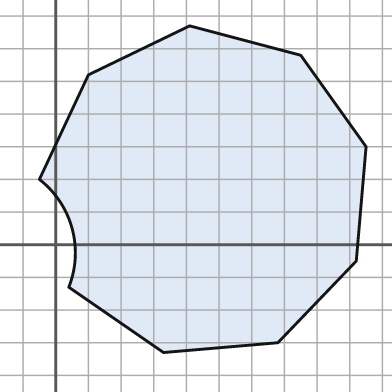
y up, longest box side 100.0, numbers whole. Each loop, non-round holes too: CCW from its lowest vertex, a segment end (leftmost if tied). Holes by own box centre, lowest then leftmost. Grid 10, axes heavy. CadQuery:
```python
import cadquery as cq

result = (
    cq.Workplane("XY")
    .moveTo(33.0, -33.0)
    .lineTo(68.0, -30.0)
    .lineTo(92.0, -5.0)
    .lineTo(95.0, 30.0)
    .lineTo(75.0, 58.0)
    .lineTo(41.0, 67.0)
    .lineTo(10.0, 52.0)
    .lineTo(-5.0, 20.0)
    .threePointArc((5.0, 5.0), (4.0, -13.0))
    .close()
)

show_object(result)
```